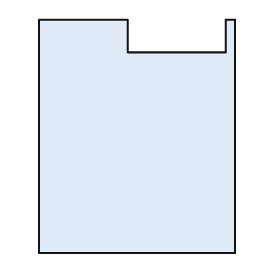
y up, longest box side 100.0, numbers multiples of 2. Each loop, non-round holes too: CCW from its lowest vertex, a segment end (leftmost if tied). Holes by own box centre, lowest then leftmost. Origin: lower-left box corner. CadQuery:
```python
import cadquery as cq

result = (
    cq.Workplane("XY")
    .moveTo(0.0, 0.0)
    .lineTo(84.0, 0.0)
    .lineTo(84.0, 100.0)
    .lineTo(80.0, 100.0)
    .lineTo(80.0, 86.0)
    .lineTo(38.0, 86.0)
    .lineTo(38.0, 100.0)
    .lineTo(0.0, 100.0)
    .close()
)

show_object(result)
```